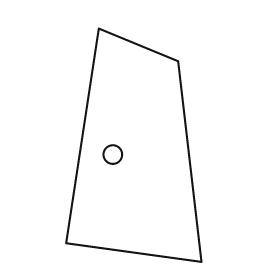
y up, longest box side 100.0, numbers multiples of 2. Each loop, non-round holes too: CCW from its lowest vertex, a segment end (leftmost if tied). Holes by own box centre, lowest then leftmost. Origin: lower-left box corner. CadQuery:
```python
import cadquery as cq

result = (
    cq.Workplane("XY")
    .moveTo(58.0, 0.0)
    .lineTo(48.0, 86.0)
    .lineTo(14.0, 100.0)
    .lineTo(0.0, 8.0)
    .close()
    .moveTo(20.0, 46.0)
    .circle(4.0)
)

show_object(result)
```